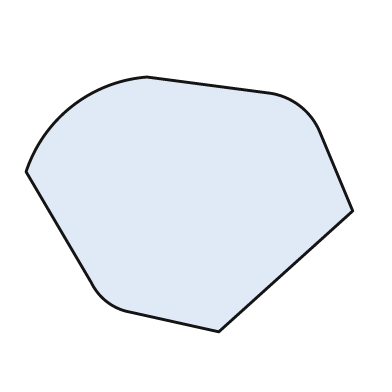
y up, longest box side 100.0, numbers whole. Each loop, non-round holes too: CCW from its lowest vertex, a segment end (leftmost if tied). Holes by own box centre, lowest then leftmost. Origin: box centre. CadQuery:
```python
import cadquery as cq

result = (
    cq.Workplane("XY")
    .moveTo(9.0, -39.0)
    .lineTo(50.0, -2.0)
    .lineTo(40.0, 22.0)
    .threePointArc((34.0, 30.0), (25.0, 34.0))
    .lineTo(-13.0, 39.0)
    .threePointArc((-36.0, 30.0), (-50.0, 10.0))
    .lineTo(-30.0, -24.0)
    .threePointArc((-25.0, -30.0), (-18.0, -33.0))
    .close()
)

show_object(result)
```